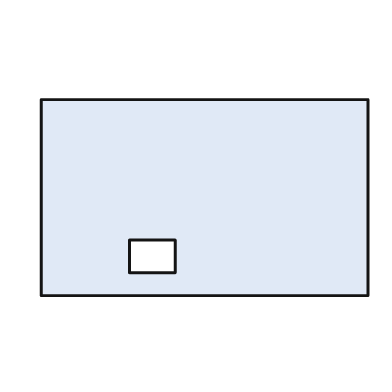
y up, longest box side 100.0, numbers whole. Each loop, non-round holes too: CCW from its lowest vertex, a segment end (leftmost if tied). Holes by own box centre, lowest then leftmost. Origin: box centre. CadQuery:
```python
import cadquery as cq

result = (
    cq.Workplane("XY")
    .moveTo(-50.0, -30.0)
    .lineTo(50.0, -30.0)
    .lineTo(50.0, 30.0)
    .lineTo(-50.0, 30.0)
    .close()
    .moveTo(-23.0, -23.0)
    .lineTo(-9.0, -23.0)
    .lineTo(-9.0, -13.0)
    .lineTo(-23.0, -13.0)
    .close()
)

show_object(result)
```